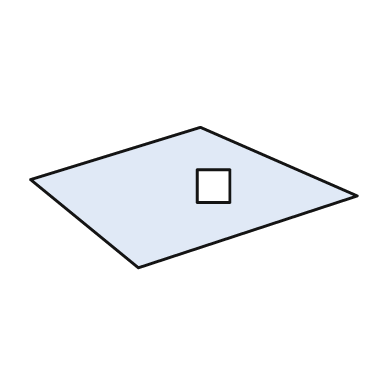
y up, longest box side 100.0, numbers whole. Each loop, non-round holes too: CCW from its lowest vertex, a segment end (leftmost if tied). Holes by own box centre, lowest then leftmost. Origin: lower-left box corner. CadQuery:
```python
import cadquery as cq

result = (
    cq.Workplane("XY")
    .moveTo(33.0, 0.0)
    .lineTo(100.0, 22.0)
    .lineTo(52.0, 43.0)
    .lineTo(0.0, 27.0)
    .close()
    .moveTo(51.0, 20.0)
    .lineTo(61.0, 20.0)
    .lineTo(61.0, 30.0)
    .lineTo(51.0, 30.0)
    .close()
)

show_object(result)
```